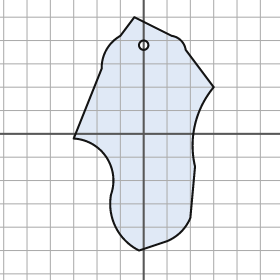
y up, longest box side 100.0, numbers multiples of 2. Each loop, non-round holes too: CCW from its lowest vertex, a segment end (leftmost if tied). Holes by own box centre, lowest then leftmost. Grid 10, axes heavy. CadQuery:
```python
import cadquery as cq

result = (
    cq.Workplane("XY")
    .moveTo(-2.0, -50.0)
    .lineTo(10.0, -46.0)
    .threePointArc((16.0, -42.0), (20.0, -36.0))
    .lineTo(22.0, -14.0)
    .threePointArc((22.0, 4.0), (30.0, 20.0))
    .lineTo(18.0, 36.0)
    .threePointArc((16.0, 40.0), (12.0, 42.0))
    .lineTo(-4.0, 50.0)
    .lineTo(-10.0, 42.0)
    .threePointArc((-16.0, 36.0), (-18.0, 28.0))
    .lineTo(-30.0, -2.0)
    .threePointArc((-16.0, -10.0), (-14.0, -26.0))
    .threePointArc((-12.0, -40.0), (-2.0, -50.0))
    .close()
    .moveTo(0.0, 38.0)
    .circle(2.0)
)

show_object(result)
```